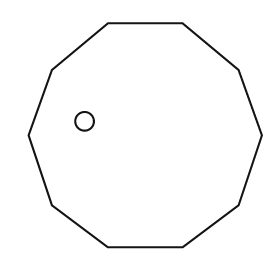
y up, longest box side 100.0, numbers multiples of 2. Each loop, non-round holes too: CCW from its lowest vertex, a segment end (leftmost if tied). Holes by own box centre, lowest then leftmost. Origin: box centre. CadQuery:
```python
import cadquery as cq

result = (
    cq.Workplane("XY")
    .moveTo(-16.0, -48.0)
    .lineTo(16.0, -48.0)
    .lineTo(40.0, -30.0)
    .lineTo(50.0, 0.0)
    .lineTo(40.0, 28.0)
    .lineTo(16.0, 48.0)
    .lineTo(-16.0, 48.0)
    .lineTo(-40.0, 28.0)
    .lineTo(-50.0, 0.0)
    .lineTo(-40.0, -30.0)
    .close()
    .moveTo(-26.0, 6.0)
    .circle(4.0)
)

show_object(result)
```